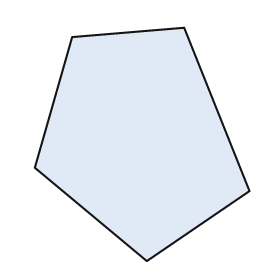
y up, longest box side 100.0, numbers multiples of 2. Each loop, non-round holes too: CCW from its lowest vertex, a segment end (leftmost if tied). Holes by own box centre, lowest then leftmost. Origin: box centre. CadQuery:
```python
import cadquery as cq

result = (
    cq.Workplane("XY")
    .moveTo(2.0, -50.0)
    .lineTo(46.0, -20.0)
    .lineTo(18.0, 50.0)
    .lineTo(-30.0, 46.0)
    .lineTo(-46.0, -10.0)
    .close()
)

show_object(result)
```